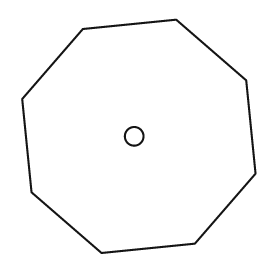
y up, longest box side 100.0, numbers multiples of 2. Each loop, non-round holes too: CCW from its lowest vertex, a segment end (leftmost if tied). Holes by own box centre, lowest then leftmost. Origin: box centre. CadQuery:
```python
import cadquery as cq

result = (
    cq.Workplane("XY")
    .moveTo(-16.0, -50.0)
    .lineTo(24.0, -46.0)
    .lineTo(50.0, -16.0)
    .lineTo(46.0, 24.0)
    .lineTo(16.0, 50.0)
    .lineTo(-24.0, 46.0)
    .lineTo(-50.0, 16.0)
    .lineTo(-46.0, -24.0)
    .close()
    .moveTo(-2.0, 0.0)
    .circle(4.0)
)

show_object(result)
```